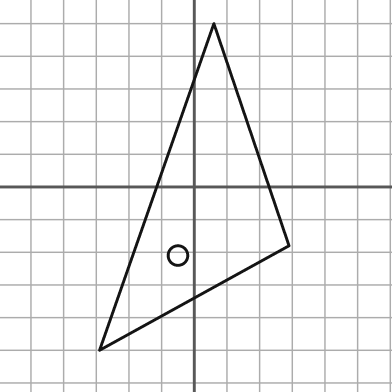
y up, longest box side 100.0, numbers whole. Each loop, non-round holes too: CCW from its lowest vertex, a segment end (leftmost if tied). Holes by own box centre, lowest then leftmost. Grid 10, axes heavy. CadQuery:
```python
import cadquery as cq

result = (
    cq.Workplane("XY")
    .moveTo(-29.0, -50.0)
    .lineTo(29.0, -18.0)
    .lineTo(6.0, 50.0)
    .close()
    .moveTo(-5.0, -21.0)
    .circle(3.0)
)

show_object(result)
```